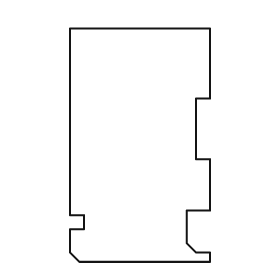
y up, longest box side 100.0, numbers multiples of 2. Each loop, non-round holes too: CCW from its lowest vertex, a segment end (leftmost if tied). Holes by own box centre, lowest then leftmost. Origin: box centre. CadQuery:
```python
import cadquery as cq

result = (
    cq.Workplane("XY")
    .moveTo(-26.0, -50.0)
    .lineTo(30.0, -50.0)
    .lineTo(30.0, -46.0)
    .lineTo(24.0, -46.0)
    .lineTo(20.0, -42.0)
    .lineTo(20.0, -28.0)
    .lineTo(30.0, -28.0)
    .lineTo(30.0, -6.0)
    .lineTo(24.0, -6.0)
    .lineTo(24.0, 20.0)
    .lineTo(30.0, 20.0)
    .lineTo(30.0, 50.0)
    .lineTo(-30.0, 50.0)
    .lineTo(-30.0, -30.0)
    .lineTo(-24.0, -30.0)
    .lineTo(-24.0, -36.0)
    .lineTo(-30.0, -36.0)
    .lineTo(-30.0, -46.0)
    .close()
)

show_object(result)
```